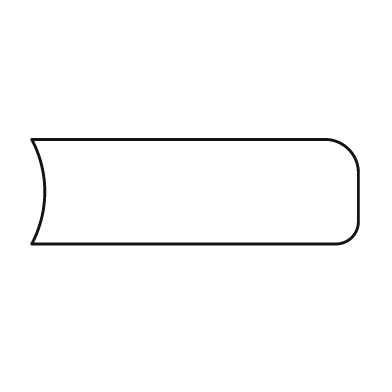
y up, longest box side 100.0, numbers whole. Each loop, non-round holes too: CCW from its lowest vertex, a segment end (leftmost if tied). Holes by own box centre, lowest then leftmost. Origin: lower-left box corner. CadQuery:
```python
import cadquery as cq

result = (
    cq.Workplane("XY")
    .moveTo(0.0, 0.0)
    .lineTo(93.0, 0.0)
    .threePointArc((98.0, 2.0), (100.0, 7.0))
    .lineTo(100.0, 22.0)
    .threePointArc((97.0, 29.0), (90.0, 32.0))
    .lineTo(0.0, 32.0)
    .threePointArc((4.0, 16.0), (0.0, 0.0))
    .close()
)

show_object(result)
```